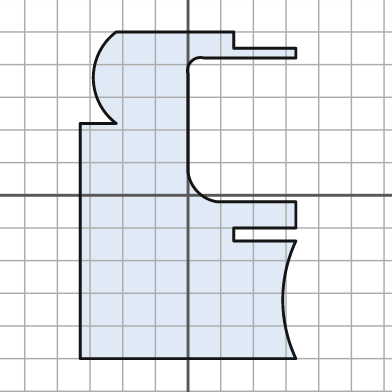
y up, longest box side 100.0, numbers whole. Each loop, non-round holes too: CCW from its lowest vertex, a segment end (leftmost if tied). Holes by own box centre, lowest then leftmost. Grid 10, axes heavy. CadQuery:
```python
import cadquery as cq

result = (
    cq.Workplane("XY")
    .moveTo(-33.0, -50.0)
    .lineTo(33.0, -50.0)
    .threePointArc((29.0, -32.0), (33.0, -14.0))
    .lineTo(14.0, -14.0)
    .lineTo(14.0, -10.0)
    .lineTo(33.0, -10.0)
    .lineTo(33.0, -2.0)
    .lineTo(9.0, -2.0)
    .threePointArc((3.0, 1.0), (0.0, 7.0))
    .lineTo(0.0, 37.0)
    .threePointArc((1.0, 41.0), (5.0, 42.0))
    .lineTo(33.0, 42.0)
    .lineTo(33.0, 45.0)
    .lineTo(14.0, 45.0)
    .lineTo(14.0, 50.0)
    .lineTo(-22.0, 50.0)
    .threePointArc((-29.0, 36.0), (-22.0, 22.0))
    .lineTo(-33.0, 22.0)
    .close()
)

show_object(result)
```